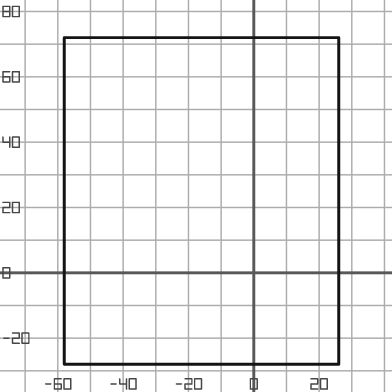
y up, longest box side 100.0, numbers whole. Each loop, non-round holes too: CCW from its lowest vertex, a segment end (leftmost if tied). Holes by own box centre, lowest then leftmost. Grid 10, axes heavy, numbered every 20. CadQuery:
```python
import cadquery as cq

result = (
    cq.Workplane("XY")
    .moveTo(-58.0, -28.0)
    .lineTo(26.0, -28.0)
    .lineTo(26.0, 72.0)
    .lineTo(-58.0, 72.0)
    .close()
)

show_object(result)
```